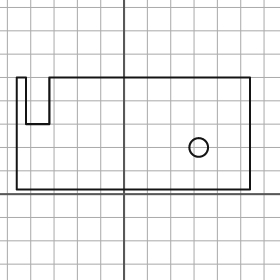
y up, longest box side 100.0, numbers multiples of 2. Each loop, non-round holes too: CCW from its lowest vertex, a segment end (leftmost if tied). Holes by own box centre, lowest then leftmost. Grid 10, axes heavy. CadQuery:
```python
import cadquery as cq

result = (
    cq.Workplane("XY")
    .moveTo(-46.0, 2.0)
    .lineTo(54.0, 2.0)
    .lineTo(54.0, 50.0)
    .lineTo(-32.0, 50.0)
    .lineTo(-32.0, 30.0)
    .lineTo(-42.0, 30.0)
    .lineTo(-42.0, 50.0)
    .lineTo(-46.0, 50.0)
    .close()
    .moveTo(32.0, 20.0)
    .circle(4.0)
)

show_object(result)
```